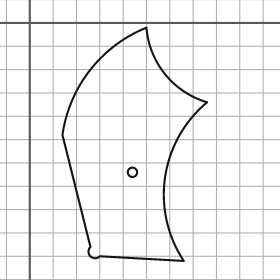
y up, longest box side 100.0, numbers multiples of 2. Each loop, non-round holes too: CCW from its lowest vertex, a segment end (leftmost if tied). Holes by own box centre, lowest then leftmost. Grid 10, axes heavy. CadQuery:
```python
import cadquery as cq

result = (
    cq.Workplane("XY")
    .moveTo(66.0, -102.0)
    .threePointArc((58.0, -66.0), (76.0, -34.0))
    .threePointArc((58.0, -22.0), (50.0, -2.0))
    .threePointArc((26.0, -20.0), (14.0, -48.0))
    .lineTo(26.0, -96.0)
    .threePointArc((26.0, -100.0), (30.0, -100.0))
    .close()
    .moveTo(44.0, -64.0)
    .circle(2.0)
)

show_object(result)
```